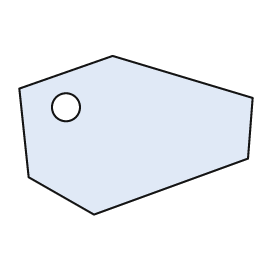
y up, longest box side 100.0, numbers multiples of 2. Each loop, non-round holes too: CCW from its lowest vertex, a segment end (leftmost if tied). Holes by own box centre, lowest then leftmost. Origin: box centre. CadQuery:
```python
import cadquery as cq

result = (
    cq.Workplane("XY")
    .moveTo(-18.0, -34.0)
    .lineTo(48.0, -10.0)
    .lineTo(50.0, 16.0)
    .lineTo(-10.0, 34.0)
    .lineTo(-50.0, 20.0)
    .lineTo(-46.0, -18.0)
    .close()
    .moveTo(-30.0, 12.0)
    .circle(6.0)
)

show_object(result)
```